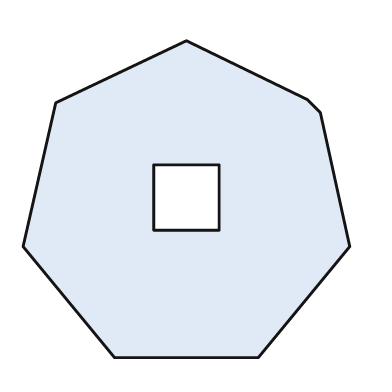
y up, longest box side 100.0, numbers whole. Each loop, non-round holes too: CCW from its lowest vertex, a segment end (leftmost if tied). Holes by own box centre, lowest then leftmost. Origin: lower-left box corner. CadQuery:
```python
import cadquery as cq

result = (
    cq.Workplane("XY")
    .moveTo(28.0, 0.0)
    .lineTo(72.0, 0.0)
    .lineTo(100.0, 34.0)
    .lineTo(91.0, 75.0)
    .lineTo(87.0, 79.0)
    .lineTo(50.0, 97.0)
    .lineTo(10.0, 78.0)
    .lineTo(0.0, 34.0)
    .close()
    .moveTo(40.0, 39.0)
    .lineTo(60.0, 39.0)
    .lineTo(60.0, 59.0)
    .lineTo(40.0, 59.0)
    .close()
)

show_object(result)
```